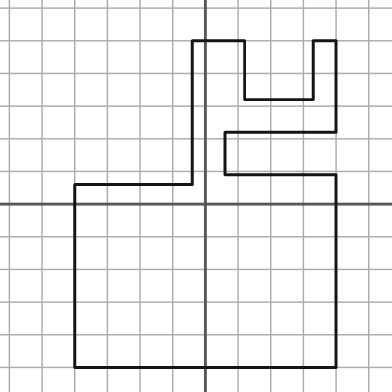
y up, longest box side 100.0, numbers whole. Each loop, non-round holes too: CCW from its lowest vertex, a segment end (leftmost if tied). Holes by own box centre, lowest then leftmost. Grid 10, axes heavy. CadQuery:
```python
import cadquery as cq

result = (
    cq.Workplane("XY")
    .moveTo(-40.0, -50.0)
    .lineTo(40.0, -50.0)
    .lineTo(40.0, 9.0)
    .lineTo(6.0, 9.0)
    .lineTo(6.0, 22.0)
    .lineTo(40.0, 22.0)
    .lineTo(40.0, 50.0)
    .lineTo(33.0, 50.0)
    .lineTo(33.0, 32.0)
    .lineTo(12.0, 32.0)
    .lineTo(12.0, 50.0)
    .lineTo(-4.0, 50.0)
    .lineTo(-4.0, 6.0)
    .lineTo(-40.0, 6.0)
    .close()
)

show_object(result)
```